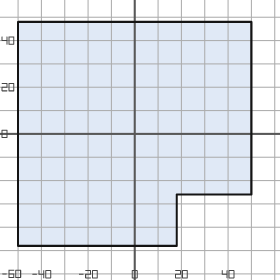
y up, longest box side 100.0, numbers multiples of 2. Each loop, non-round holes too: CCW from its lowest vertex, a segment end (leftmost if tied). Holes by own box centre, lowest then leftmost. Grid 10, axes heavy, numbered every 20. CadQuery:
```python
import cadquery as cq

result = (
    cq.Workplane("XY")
    .moveTo(-50.0, -48.0)
    .lineTo(18.0, -48.0)
    .lineTo(18.0, -26.0)
    .lineTo(50.0, -26.0)
    .lineTo(50.0, 48.0)
    .lineTo(-50.0, 48.0)
    .close()
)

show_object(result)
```